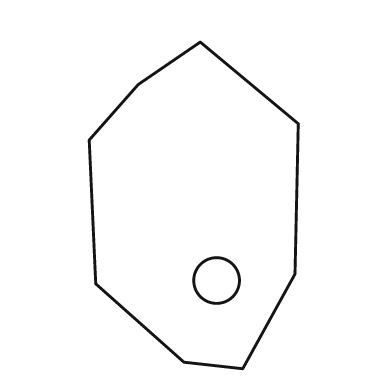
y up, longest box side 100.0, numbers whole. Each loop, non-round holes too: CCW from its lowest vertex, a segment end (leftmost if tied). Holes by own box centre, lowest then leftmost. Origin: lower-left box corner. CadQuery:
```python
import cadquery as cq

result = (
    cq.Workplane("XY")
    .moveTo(47.0, 0.0)
    .lineTo(63.0, 29.0)
    .lineTo(64.0, 75.0)
    .lineTo(34.0, 100.0)
    .lineTo(15.0, 87.0)
    .lineTo(0.0, 70.0)
    .lineTo(2.0, 26.0)
    .lineTo(29.0, 2.0)
    .close()
    .moveTo(39.0, 27.0)
    .circle(7.0)
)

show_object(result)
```